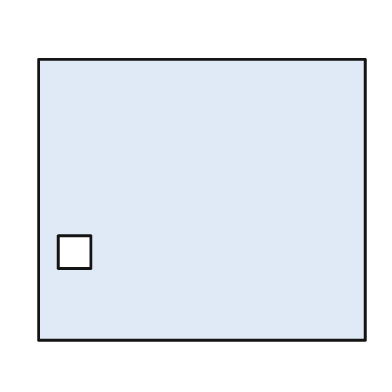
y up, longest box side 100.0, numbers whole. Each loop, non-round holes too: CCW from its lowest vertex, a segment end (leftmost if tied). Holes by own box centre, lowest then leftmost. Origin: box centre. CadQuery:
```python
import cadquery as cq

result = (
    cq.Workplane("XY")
    .moveTo(-50.0, -43.0)
    .lineTo(50.0, -43.0)
    .lineTo(50.0, 43.0)
    .lineTo(-50.0, 43.0)
    .close()
    .moveTo(-44.0, -21.0)
    .lineTo(-34.0, -21.0)
    .lineTo(-34.0, -11.0)
    .lineTo(-44.0, -11.0)
    .close()
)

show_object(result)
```